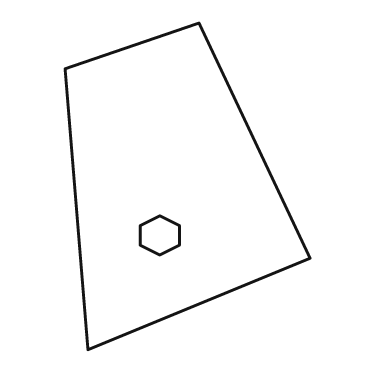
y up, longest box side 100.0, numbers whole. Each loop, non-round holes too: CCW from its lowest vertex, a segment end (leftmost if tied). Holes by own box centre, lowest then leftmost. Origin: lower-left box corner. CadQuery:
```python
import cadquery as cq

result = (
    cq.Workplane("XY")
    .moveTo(7.0, 0.0)
    .lineTo(75.0, 28.0)
    .lineTo(41.0, 100.0)
    .lineTo(0.0, 86.0)
    .close()
    .moveTo(29.0, 29.0)
    .lineTo(35.0, 32.0)
    .lineTo(35.0, 38.0)
    .lineTo(29.0, 41.0)
    .lineTo(23.0, 38.0)
    .lineTo(23.0, 32.0)
    .close()
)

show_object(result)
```